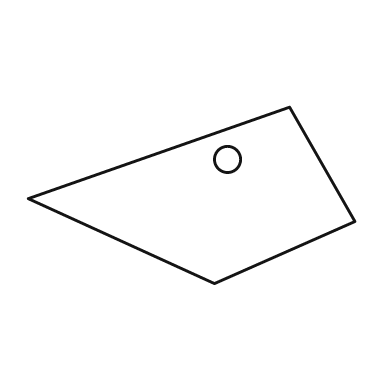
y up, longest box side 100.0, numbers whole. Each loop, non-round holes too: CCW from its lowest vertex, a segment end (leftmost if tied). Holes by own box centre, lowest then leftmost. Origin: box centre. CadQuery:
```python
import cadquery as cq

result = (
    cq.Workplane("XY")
    .moveTo(7.0, -27.0)
    .lineTo(50.0, -8.0)
    .lineTo(30.0, 27.0)
    .lineTo(-50.0, -1.0)
    .close()
    .moveTo(11.0, 11.0)
    .circle(4.0)
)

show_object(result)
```